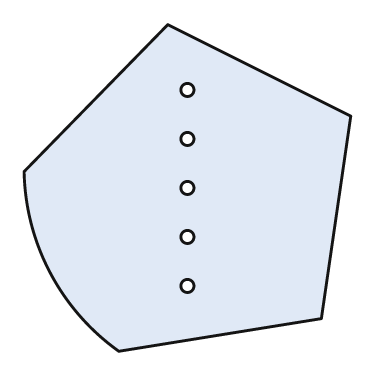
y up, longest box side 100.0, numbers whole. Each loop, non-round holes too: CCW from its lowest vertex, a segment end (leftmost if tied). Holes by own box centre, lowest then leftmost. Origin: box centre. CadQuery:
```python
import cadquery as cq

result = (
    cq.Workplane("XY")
    .moveTo(-21.0, -50.0)
    .lineTo(41.0, -40.0)
    .lineTo(50.0, 22.0)
    .lineTo(-6.0, 50.0)
    .lineTo(-50.0, 5.0)
    .threePointArc((-42.0, -26.0), (-21.0, -50.0))
    .close()
    .moveTo(0.0, -30.0)
    .circle(2.0)
    .moveTo(0.0, -15.0)
    .circle(2.0)
    .moveTo(0.0, 0.0)
    .circle(2.0)
    .moveTo(0.0, 15.0)
    .circle(2.0)
    .moveTo(0.0, 30.0)
    .circle(2.0)
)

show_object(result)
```